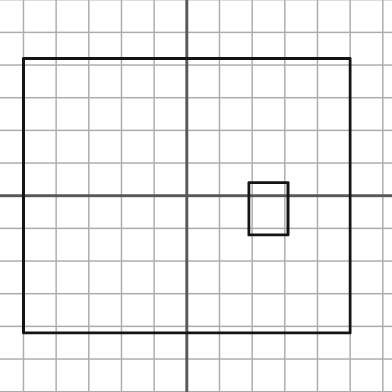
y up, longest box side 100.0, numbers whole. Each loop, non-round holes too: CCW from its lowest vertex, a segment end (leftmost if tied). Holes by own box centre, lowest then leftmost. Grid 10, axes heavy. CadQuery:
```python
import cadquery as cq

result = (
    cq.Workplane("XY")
    .moveTo(-50.0, -42.0)
    .lineTo(50.0, -42.0)
    .lineTo(50.0, 42.0)
    .lineTo(-50.0, 42.0)
    .close()
    .moveTo(19.0, -12.0)
    .lineTo(31.0, -12.0)
    .lineTo(31.0, 4.0)
    .lineTo(19.0, 4.0)
    .close()
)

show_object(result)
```